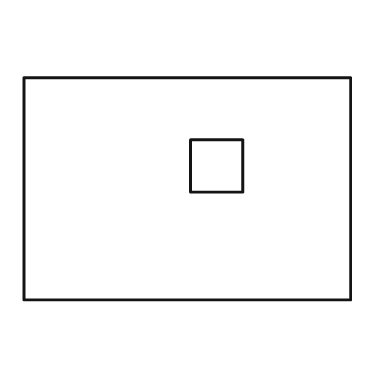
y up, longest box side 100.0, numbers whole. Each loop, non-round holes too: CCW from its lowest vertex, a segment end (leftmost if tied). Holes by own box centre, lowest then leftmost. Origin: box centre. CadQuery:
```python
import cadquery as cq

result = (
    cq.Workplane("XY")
    .moveTo(-50.0, -34.0)
    .lineTo(50.0, -34.0)
    .lineTo(50.0, 34.0)
    .lineTo(-50.0, 34.0)
    .close()
    .moveTo(1.0, -1.0)
    .lineTo(17.0, -1.0)
    .lineTo(17.0, 15.0)
    .lineTo(1.0, 15.0)
    .close()
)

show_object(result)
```